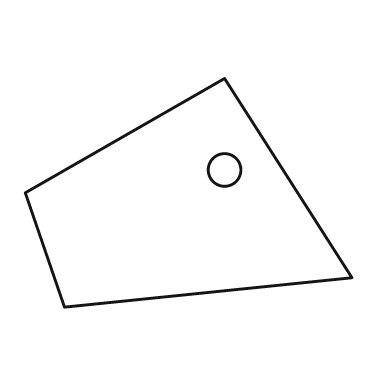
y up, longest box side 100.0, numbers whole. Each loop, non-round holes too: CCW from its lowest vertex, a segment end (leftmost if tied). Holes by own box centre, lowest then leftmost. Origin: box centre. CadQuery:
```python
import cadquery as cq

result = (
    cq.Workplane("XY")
    .moveTo(-38.0, -35.0)
    .lineTo(50.0, -26.0)
    .lineTo(11.0, 35.0)
    .lineTo(-50.0, 0.0)
    .close()
    .moveTo(11.0, 7.0)
    .circle(5.0)
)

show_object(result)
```